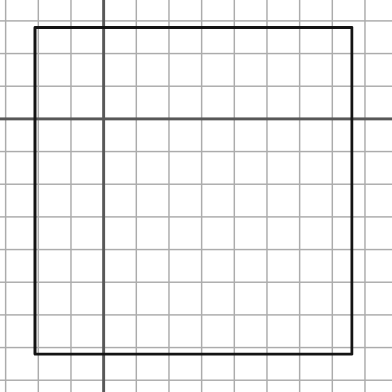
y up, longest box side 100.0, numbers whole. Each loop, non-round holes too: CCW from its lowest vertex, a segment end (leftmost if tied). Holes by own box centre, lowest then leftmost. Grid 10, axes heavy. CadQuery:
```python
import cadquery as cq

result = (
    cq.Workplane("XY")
    .moveTo(-21.0, -72.0)
    .lineTo(76.0, -72.0)
    .lineTo(76.0, 28.0)
    .lineTo(-21.0, 28.0)
    .close()
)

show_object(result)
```